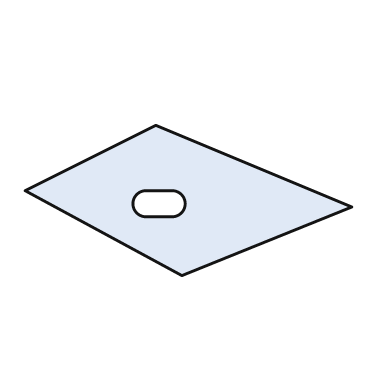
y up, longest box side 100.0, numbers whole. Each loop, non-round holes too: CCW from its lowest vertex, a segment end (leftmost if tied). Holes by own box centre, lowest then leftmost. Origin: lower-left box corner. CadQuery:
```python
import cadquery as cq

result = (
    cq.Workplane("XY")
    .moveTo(48.0, 0.0)
    .lineTo(100.0, 21.0)
    .lineTo(40.0, 46.0)
    .lineTo(0.0, 26.0)
    .close()
    .moveTo(37.0, 18.0)
    .lineTo(45.0, 18.0)
    .threePointArc((49.0, 22.0), (45.0, 26.0))
    .lineTo(37.0, 26.0)
    .threePointArc((33.0, 22.0), (37.0, 18.0))
    .close()
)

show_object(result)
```